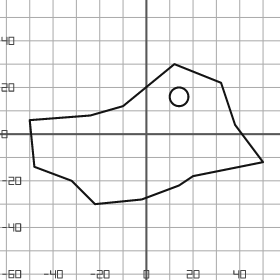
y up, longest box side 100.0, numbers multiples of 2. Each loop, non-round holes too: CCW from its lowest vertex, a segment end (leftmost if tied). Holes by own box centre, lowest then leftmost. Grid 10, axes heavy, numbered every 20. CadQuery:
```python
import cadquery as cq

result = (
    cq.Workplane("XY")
    .moveTo(-22.0, -30.0)
    .lineTo(-2.0, -28.0)
    .lineTo(14.0, -22.0)
    .lineTo(20.0, -18.0)
    .lineTo(50.0, -12.0)
    .lineTo(38.0, 4.0)
    .lineTo(32.0, 22.0)
    .lineTo(12.0, 30.0)
    .lineTo(-10.0, 12.0)
    .lineTo(-24.0, 8.0)
    .lineTo(-50.0, 6.0)
    .lineTo(-48.0, -14.0)
    .lineTo(-32.0, -20.0)
    .close()
    .moveTo(14.0, 16.0)
    .circle(4.0)
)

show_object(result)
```